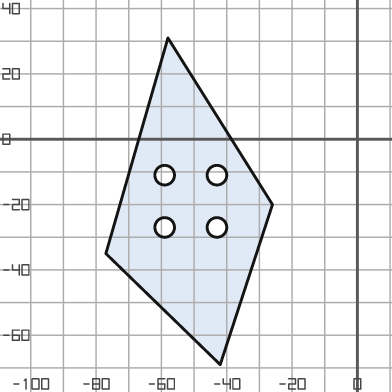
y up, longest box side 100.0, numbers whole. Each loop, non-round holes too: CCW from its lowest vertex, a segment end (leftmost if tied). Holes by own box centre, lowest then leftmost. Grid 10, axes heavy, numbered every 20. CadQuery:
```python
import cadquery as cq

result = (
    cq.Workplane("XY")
    .moveTo(-42.0, -69.0)
    .lineTo(-26.0, -20.0)
    .lineTo(-58.0, 31.0)
    .lineTo(-77.0, -35.0)
    .close()
    .moveTo(-59.0, -27.0)
    .circle(3.0)
    .moveTo(-43.0, -27.0)
    .circle(3.0)
    .moveTo(-59.0, -11.0)
    .circle(3.0)
    .moveTo(-43.0, -11.0)
    .circle(3.0)
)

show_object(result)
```